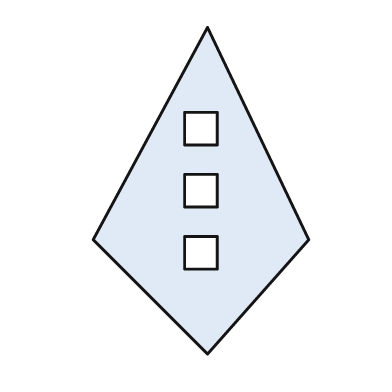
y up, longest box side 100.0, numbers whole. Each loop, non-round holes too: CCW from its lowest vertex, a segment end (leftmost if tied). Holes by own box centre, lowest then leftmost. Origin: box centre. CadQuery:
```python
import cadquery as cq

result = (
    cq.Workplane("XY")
    .moveTo(2.0, -50.0)
    .lineTo(33.0, -15.0)
    .lineTo(2.0, 50.0)
    .lineTo(-33.0, -15.0)
    .close()
    .moveTo(-5.0, -24.0)
    .lineTo(5.0, -24.0)
    .lineTo(5.0, -14.0)
    .lineTo(-5.0, -14.0)
    .close()
    .moveTo(-5.0, -5.0)
    .lineTo(5.0, -5.0)
    .lineTo(5.0, 5.0)
    .lineTo(-5.0, 5.0)
    .close()
    .moveTo(-5.0, 14.0)
    .lineTo(5.0, 14.0)
    .lineTo(5.0, 24.0)
    .lineTo(-5.0, 24.0)
    .close()
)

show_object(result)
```